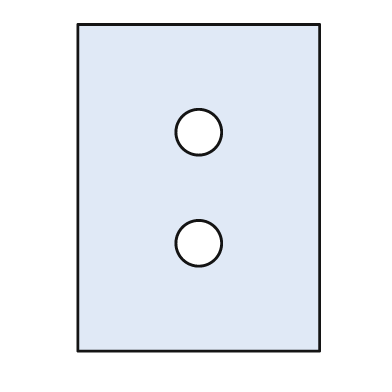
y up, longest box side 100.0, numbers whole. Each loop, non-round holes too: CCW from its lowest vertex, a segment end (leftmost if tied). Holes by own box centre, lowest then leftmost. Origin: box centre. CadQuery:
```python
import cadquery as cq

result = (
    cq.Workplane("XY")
    .moveTo(-37.0, -50.0)
    .lineTo(37.0, -50.0)
    .lineTo(37.0, 50.0)
    .lineTo(-37.0, 50.0)
    .close()
    .moveTo(0.0, -17.0)
    .circle(7.0)
    .moveTo(0.0, 17.0)
    .circle(7.0)
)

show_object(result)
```